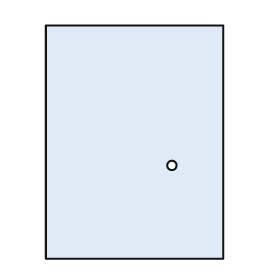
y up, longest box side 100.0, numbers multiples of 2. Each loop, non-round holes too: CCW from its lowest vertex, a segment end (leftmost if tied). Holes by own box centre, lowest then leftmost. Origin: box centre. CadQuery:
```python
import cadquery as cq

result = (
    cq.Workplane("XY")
    .moveTo(-38.0, -50.0)
    .lineTo(38.0, -50.0)
    .lineTo(38.0, 50.0)
    .lineTo(-38.0, 50.0)
    .close()
    .moveTo(16.0, -10.0)
    .circle(2.0)
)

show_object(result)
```